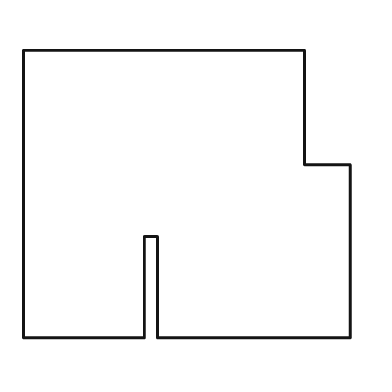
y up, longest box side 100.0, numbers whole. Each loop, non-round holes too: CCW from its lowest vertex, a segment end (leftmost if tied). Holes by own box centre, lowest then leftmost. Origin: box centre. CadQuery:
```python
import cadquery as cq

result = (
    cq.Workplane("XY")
    .moveTo(-50.0, -44.0)
    .lineTo(-13.0, -44.0)
    .lineTo(-13.0, -13.0)
    .lineTo(-9.0, -13.0)
    .lineTo(-9.0, -44.0)
    .lineTo(50.0, -44.0)
    .lineTo(50.0, 9.0)
    .lineTo(36.0, 9.0)
    .lineTo(36.0, 44.0)
    .lineTo(-50.0, 44.0)
    .close()
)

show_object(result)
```